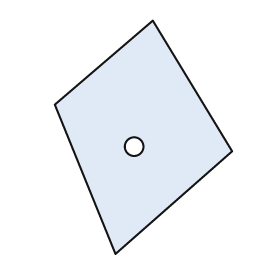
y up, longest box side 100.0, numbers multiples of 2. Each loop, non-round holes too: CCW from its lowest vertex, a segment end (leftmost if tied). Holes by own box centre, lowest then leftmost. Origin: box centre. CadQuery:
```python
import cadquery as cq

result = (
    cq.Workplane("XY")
    .moveTo(-12.0, -50.0)
    .lineTo(38.0, -6.0)
    .lineTo(4.0, 50.0)
    .lineTo(-38.0, 14.0)
    .close()
    .moveTo(-4.0, -4.0)
    .circle(4.0)
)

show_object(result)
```